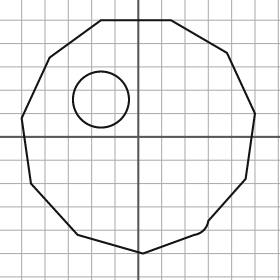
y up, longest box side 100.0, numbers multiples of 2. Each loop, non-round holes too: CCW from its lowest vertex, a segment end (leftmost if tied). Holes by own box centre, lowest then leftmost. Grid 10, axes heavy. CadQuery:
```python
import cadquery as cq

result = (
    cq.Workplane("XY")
    .moveTo(2.0, -50.0)
    .lineTo(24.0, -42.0)
    .threePointArc((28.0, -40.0), (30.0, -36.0))
    .lineTo(46.0, -18.0)
    .lineTo(50.0, 10.0)
    .lineTo(38.0, 36.0)
    .lineTo(14.0, 50.0)
    .lineTo(-16.0, 50.0)
    .lineTo(-38.0, 34.0)
    .lineTo(-50.0, 8.0)
    .lineTo(-46.0, -20.0)
    .lineTo(-26.0, -42.0)
    .close()
    .moveTo(-16.0, 16.0)
    .circle(12.0)
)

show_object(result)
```